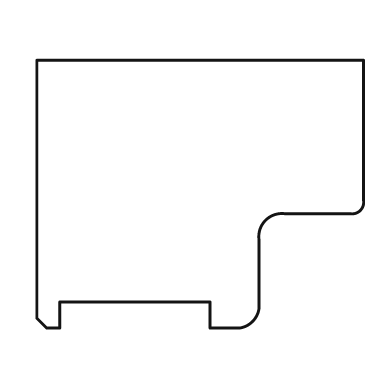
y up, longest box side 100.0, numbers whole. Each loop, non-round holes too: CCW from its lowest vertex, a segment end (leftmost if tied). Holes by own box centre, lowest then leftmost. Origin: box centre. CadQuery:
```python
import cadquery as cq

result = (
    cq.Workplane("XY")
    .moveTo(-47.0, -41.0)
    .lineTo(-43.0, -41.0)
    .lineTo(-43.0, -33.0)
    .lineTo(3.0, -33.0)
    .lineTo(3.0, -41.0)
    .lineTo(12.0, -41.0)
    .threePointArc((16.0, -39.0), (18.0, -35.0))
    .lineTo(18.0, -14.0)
    .threePointArc((20.0, -8.0), (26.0, -6.0))
    .lineTo(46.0, -6.0)
    .threePointArc((49.0, -5.0), (50.0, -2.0))
    .lineTo(50.0, 41.0)
    .lineTo(-50.0, 41.0)
    .lineTo(-50.0, -38.0)
    .close()
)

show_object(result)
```